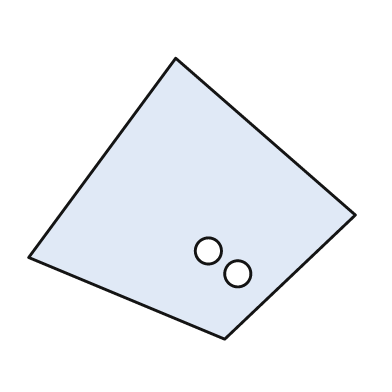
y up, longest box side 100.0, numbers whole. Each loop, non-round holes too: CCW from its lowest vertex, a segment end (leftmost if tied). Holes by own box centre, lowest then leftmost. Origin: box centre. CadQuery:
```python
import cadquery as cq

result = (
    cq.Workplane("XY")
    .moveTo(10.0, -43.0)
    .lineTo(50.0, -5.0)
    .lineTo(-5.0, 43.0)
    .lineTo(-50.0, -18.0)
    .close()
    .moveTo(14.0, -23.0)
    .circle(4.0)
    .moveTo(5.0, -16.0)
    .circle(4.0)
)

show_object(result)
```